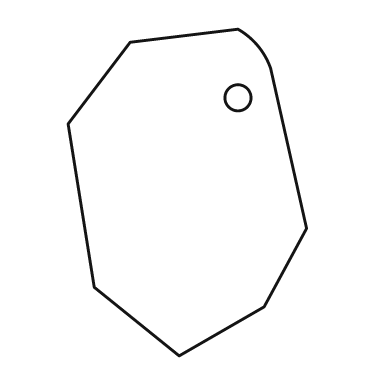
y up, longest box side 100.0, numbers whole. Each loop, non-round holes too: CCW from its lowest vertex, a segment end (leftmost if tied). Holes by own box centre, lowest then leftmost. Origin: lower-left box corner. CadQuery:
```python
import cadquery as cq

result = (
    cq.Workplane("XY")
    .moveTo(34.0, 0.0)
    .lineTo(60.0, 15.0)
    .lineTo(73.0, 39.0)
    .lineTo(62.0, 88.0)
    .threePointArc((58.0, 95.0), (52.0, 100.0))
    .lineTo(19.0, 96.0)
    .lineTo(0.0, 71.0)
    .lineTo(8.0, 21.0)
    .close()
    .moveTo(52.0, 79.0)
    .circle(4.0)
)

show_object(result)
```